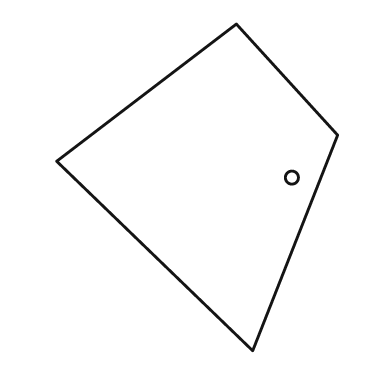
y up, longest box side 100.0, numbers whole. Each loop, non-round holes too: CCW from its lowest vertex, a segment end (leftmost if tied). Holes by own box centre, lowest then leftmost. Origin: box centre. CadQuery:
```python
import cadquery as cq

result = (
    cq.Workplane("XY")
    .moveTo(17.0, -50.0)
    .lineTo(43.0, 16.0)
    .lineTo(12.0, 50.0)
    .lineTo(-43.0, 8.0)
    .close()
    .moveTo(29.0, 3.0)
    .circle(2.0)
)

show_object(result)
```